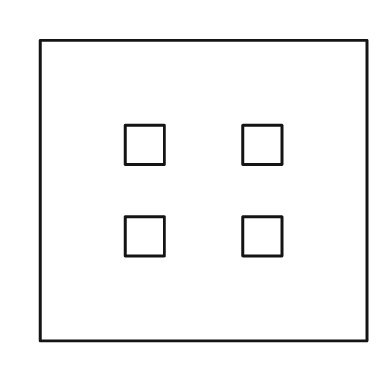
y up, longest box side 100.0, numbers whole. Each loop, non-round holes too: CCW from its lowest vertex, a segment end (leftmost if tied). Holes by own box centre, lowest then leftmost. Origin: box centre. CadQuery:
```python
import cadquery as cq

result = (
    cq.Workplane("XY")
    .moveTo(-50.0, -46.0)
    .lineTo(50.0, -46.0)
    .lineTo(50.0, 46.0)
    .lineTo(-50.0, 46.0)
    .close()
    .moveTo(-24.0, -20.0)
    .lineTo(-12.0, -20.0)
    .lineTo(-12.0, -8.0)
    .lineTo(-24.0, -8.0)
    .close()
    .moveTo(12.0, -20.0)
    .lineTo(24.0, -20.0)
    .lineTo(24.0, -8.0)
    .lineTo(12.0, -8.0)
    .close()
    .moveTo(-24.0, 8.0)
    .lineTo(-12.0, 8.0)
    .lineTo(-12.0, 20.0)
    .lineTo(-24.0, 20.0)
    .close()
    .moveTo(12.0, 8.0)
    .lineTo(24.0, 8.0)
    .lineTo(24.0, 20.0)
    .lineTo(12.0, 20.0)
    .close()
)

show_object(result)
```